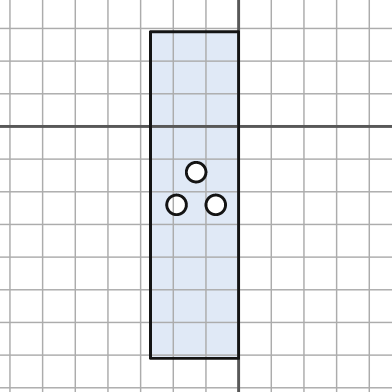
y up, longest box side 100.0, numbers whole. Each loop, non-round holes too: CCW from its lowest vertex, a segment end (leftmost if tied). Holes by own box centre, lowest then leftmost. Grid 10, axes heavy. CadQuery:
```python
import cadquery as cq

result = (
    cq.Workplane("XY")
    .moveTo(-27.0, -71.0)
    .lineTo(0.0, -71.0)
    .lineTo(0.0, 29.0)
    .lineTo(-27.0, 29.0)
    .close()
    .moveTo(-19.0, -24.0)
    .circle(3.0)
    .moveTo(-7.0, -24.0)
    .circle(3.0)
    .moveTo(-13.0, -14.0)
    .circle(3.0)
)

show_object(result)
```